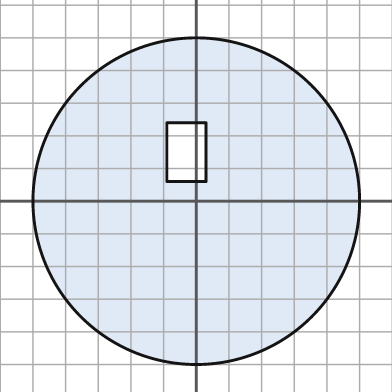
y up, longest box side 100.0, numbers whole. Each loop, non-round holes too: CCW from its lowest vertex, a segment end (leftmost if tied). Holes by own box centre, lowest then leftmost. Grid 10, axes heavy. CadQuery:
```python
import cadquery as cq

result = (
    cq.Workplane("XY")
    .moveTo(0.0, 0.0)
    .circle(50.0)
    .moveTo(-9.0, 6.0)
    .lineTo(3.0, 6.0)
    .lineTo(3.0, 24.0)
    .lineTo(-9.0, 24.0)
    .close()
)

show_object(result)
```